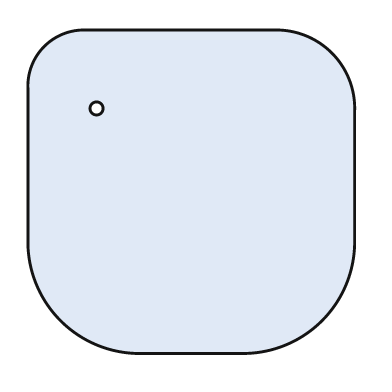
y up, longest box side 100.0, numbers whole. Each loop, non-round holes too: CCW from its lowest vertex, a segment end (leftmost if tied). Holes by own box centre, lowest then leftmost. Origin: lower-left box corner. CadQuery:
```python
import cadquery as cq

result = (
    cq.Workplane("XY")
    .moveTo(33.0, 0.0)
    .lineTo(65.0, 0.0)
    .threePointArc((90.0, 10.0), (100.0, 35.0))
    .lineTo(100.0, 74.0)
    .threePointArc((93.0, 92.0), (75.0, 99.0))
    .lineTo(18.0, 99.0)
    .threePointArc((5.0, 94.0), (0.0, 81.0))
    .lineTo(0.0, 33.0)
    .threePointArc((10.0, 10.0), (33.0, 0.0))
    .close()
    .moveTo(21.0, 75.0)
    .circle(2.0)
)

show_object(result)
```